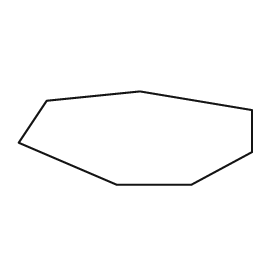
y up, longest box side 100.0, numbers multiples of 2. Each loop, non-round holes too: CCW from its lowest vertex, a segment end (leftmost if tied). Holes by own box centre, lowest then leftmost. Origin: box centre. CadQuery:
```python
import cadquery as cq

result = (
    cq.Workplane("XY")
    .moveTo(-8.0, -20.0)
    .lineTo(24.0, -20.0)
    .lineTo(50.0, -6.0)
    .lineTo(50.0, 12.0)
    .lineTo(2.0, 20.0)
    .lineTo(-38.0, 16.0)
    .lineTo(-50.0, -2.0)
    .close()
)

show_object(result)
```